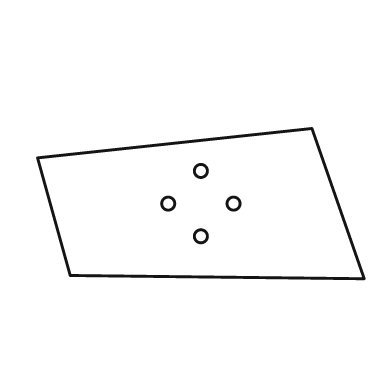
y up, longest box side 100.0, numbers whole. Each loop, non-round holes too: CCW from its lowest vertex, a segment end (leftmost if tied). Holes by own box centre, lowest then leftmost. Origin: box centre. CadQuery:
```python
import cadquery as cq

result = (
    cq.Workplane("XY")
    .moveTo(50.0, -23.0)
    .lineTo(34.0, 23.0)
    .lineTo(-50.0, 14.0)
    .lineTo(-40.0, -22.0)
    .close()
    .moveTo(0.0, -10.0)
    .circle(2.0)
    .moveTo(-10.0, 0.0)
    .circle(2.0)
    .moveTo(10.0, 0.0)
    .circle(2.0)
    .moveTo(0.0, 10.0)
    .circle(2.0)
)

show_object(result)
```